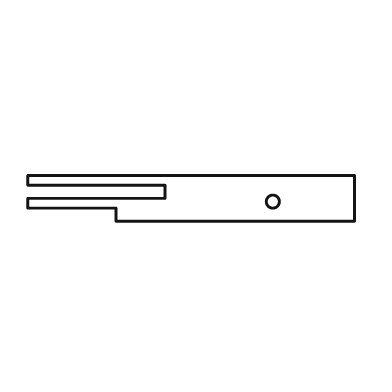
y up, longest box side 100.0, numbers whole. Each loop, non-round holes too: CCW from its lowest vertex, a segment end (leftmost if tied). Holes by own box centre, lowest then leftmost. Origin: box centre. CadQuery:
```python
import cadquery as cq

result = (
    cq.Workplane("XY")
    .moveTo(-23.0, -7.0)
    .lineTo(50.0, -7.0)
    .lineTo(50.0, 7.0)
    .lineTo(-50.0, 7.0)
    .lineTo(-50.0, 4.0)
    .lineTo(-8.0, 4.0)
    .lineTo(-8.0, 0.0)
    .lineTo(-50.0, 0.0)
    .lineTo(-50.0, -3.0)
    .lineTo(-23.0, -3.0)
    .close()
    .moveTo(25.0, -1.0)
    .circle(2.0)
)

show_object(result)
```